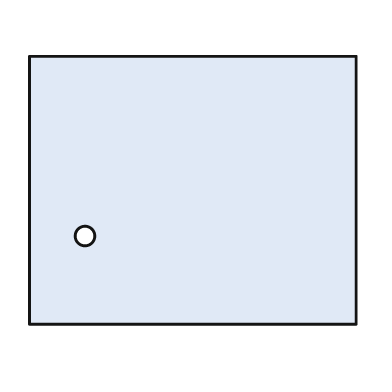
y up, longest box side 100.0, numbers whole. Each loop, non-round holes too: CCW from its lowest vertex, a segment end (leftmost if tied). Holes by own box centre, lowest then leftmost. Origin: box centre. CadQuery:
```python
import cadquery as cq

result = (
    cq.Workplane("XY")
    .moveTo(-50.0, -41.0)
    .lineTo(50.0, -41.0)
    .lineTo(50.0, 41.0)
    .lineTo(-50.0, 41.0)
    .close()
    .moveTo(-33.0, -14.0)
    .circle(3.0)
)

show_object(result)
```